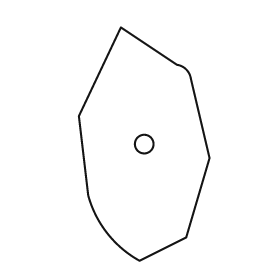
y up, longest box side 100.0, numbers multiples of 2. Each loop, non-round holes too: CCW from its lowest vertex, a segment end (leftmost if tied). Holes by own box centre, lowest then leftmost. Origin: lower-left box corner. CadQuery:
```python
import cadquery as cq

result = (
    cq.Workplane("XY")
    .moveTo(26.0, 0.0)
    .lineTo(46.0, 10.0)
    .lineTo(56.0, 44.0)
    .lineTo(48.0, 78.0)
    .threePointArc((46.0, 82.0), (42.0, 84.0))
    .lineTo(18.0, 100.0)
    .lineTo(0.0, 62.0)
    .lineTo(4.0, 28.0)
    .threePointArc((12.0, 12.0), (26.0, 0.0))
    .close()
    .moveTo(28.0, 50.0)
    .circle(4.0)
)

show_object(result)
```